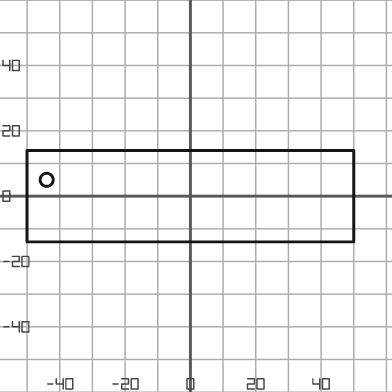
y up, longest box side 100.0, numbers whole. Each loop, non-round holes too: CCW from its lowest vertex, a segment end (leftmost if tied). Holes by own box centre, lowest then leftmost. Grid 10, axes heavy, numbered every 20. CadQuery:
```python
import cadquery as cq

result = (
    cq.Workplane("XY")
    .moveTo(-50.0, -14.0)
    .lineTo(50.0, -14.0)
    .lineTo(50.0, 14.0)
    .lineTo(-50.0, 14.0)
    .close()
    .moveTo(-44.0, 5.0)
    .circle(2.0)
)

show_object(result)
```